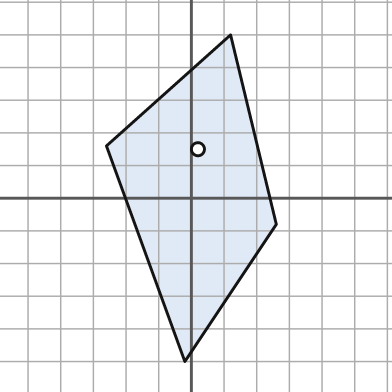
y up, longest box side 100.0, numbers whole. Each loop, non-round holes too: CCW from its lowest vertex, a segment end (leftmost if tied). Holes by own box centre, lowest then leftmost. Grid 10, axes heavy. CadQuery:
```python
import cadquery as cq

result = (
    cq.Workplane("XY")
    .moveTo(-2.0, -50.0)
    .lineTo(26.0, -8.0)
    .lineTo(12.0, 50.0)
    .lineTo(-26.0, 16.0)
    .close()
    .moveTo(2.0, 15.0)
    .circle(2.0)
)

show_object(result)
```